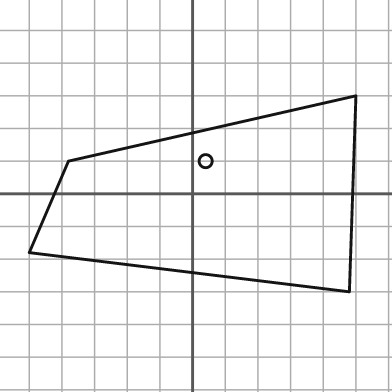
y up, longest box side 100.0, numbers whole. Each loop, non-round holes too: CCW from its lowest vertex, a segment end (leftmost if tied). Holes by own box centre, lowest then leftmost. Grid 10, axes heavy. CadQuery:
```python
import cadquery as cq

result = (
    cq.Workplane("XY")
    .moveTo(48.0, -30.0)
    .lineTo(50.0, 30.0)
    .lineTo(-38.0, 10.0)
    .lineTo(-50.0, -18.0)
    .close()
    .moveTo(4.0, 10.0)
    .circle(2.0)
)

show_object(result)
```